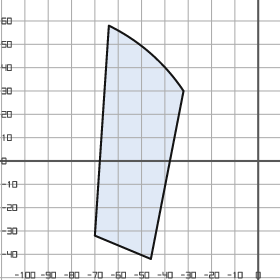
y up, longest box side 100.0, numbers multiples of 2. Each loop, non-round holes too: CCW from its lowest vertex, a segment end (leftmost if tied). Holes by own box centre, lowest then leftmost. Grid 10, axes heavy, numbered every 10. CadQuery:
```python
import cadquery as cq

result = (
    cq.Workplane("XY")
    .moveTo(-46.0, -42.0)
    .lineTo(-32.0, 30.0)
    .threePointArc((-46.0, 46.0), (-64.0, 58.0))
    .lineTo(-70.0, -32.0)
    .close()
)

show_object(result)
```